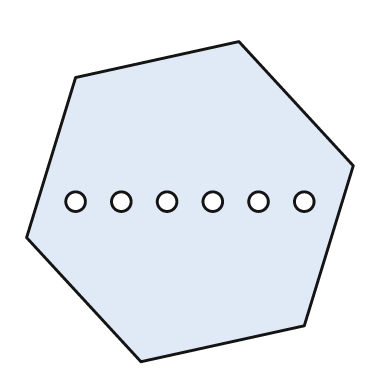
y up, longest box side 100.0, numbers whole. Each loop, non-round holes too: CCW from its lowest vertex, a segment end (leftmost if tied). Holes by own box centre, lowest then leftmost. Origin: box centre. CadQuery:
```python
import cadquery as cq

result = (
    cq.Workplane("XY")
    .moveTo(-15.0, -49.0)
    .lineTo(35.0, -38.0)
    .lineTo(50.0, 11.0)
    .lineTo(15.0, 49.0)
    .lineTo(-35.0, 38.0)
    .lineTo(-50.0, -11.0)
    .close()
    .moveTo(-35.0, 0.0)
    .circle(3.0)
    .moveTo(-21.0, 0.0)
    .circle(3.0)
    .moveTo(-7.0, 0.0)
    .circle(3.0)
    .moveTo(7.0, 0.0)
    .circle(3.0)
    .moveTo(21.0, 0.0)
    .circle(3.0)
    .moveTo(35.0, 0.0)
    .circle(3.0)
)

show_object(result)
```